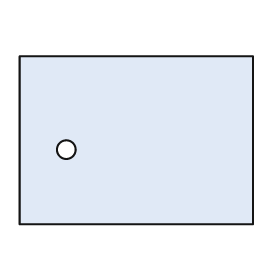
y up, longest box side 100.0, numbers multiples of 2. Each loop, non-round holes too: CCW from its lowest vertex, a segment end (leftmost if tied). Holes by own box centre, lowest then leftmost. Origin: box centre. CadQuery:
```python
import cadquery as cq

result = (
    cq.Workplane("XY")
    .moveTo(-50.0, -36.0)
    .lineTo(50.0, -36.0)
    .lineTo(50.0, 36.0)
    .lineTo(-50.0, 36.0)
    .close()
    .moveTo(-30.0, -4.0)
    .circle(4.0)
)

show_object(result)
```